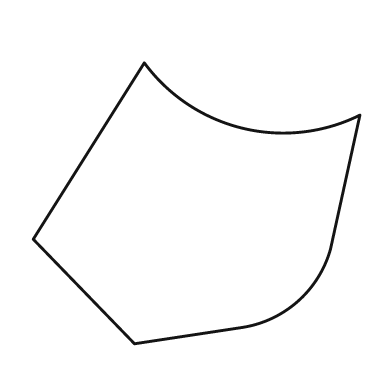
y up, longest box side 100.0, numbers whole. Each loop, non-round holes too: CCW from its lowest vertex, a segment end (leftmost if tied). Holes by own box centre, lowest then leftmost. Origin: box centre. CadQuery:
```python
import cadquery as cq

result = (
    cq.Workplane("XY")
    .moveTo(-19.0, -43.0)
    .lineTo(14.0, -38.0)
    .threePointArc((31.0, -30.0), (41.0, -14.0))
    .lineTo(50.0, 27.0)
    .threePointArc((14.0, 23.0), (-16.0, 43.0))
    .lineTo(-50.0, -11.0)
    .close()
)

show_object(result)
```